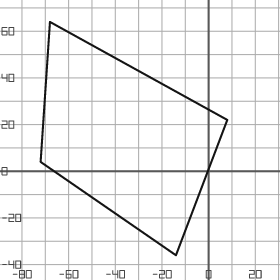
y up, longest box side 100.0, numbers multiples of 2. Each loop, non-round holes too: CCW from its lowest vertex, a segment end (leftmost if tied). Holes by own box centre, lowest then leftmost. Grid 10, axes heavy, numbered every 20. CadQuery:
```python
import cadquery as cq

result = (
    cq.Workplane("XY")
    .moveTo(-14.0, -36.0)
    .lineTo(8.0, 22.0)
    .lineTo(-68.0, 64.0)
    .lineTo(-72.0, 4.0)
    .close()
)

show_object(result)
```